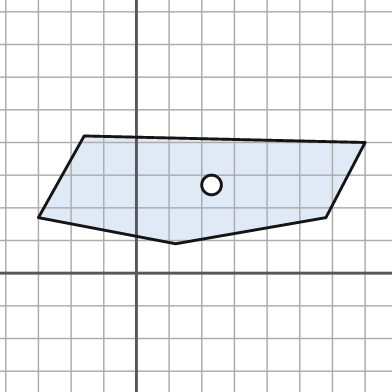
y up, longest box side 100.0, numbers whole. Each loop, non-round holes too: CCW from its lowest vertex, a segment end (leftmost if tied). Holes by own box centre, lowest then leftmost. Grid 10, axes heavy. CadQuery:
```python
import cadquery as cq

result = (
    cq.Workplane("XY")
    .moveTo(12.0, 9.0)
    .lineTo(58.0, 17.0)
    .lineTo(70.0, 40.0)
    .lineTo(-16.0, 42.0)
    .lineTo(-30.0, 17.0)
    .close()
    .moveTo(23.0, 27.0)
    .circle(3.0)
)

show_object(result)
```